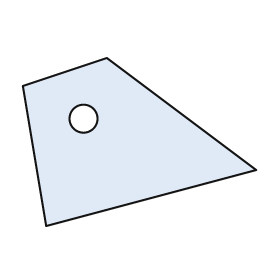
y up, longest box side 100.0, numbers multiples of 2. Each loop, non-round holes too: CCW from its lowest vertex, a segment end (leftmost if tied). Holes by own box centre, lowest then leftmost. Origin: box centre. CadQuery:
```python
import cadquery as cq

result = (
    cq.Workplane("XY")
    .moveTo(-40.0, -36.0)
    .lineTo(50.0, -12.0)
    .lineTo(-14.0, 36.0)
    .lineTo(-50.0, 24.0)
    .close()
    .moveTo(-24.0, 10.0)
    .circle(6.0)
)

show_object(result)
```